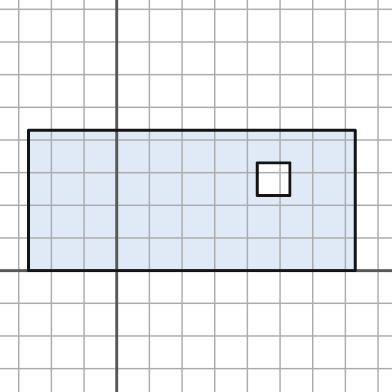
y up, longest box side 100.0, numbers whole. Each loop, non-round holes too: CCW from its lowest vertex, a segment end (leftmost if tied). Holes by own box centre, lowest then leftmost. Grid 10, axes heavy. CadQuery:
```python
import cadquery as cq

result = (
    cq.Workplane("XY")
    .moveTo(-27.0, 0.0)
    .lineTo(73.0, 0.0)
    .lineTo(73.0, 43.0)
    .lineTo(-27.0, 43.0)
    .close()
    .moveTo(43.0, 23.0)
    .lineTo(53.0, 23.0)
    .lineTo(53.0, 33.0)
    .lineTo(43.0, 33.0)
    .close()
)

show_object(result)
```